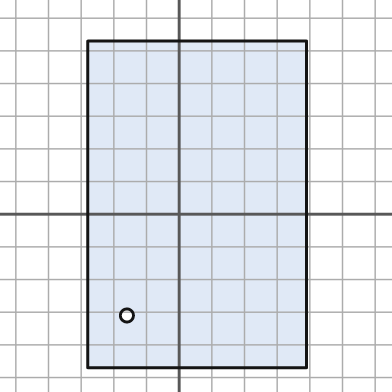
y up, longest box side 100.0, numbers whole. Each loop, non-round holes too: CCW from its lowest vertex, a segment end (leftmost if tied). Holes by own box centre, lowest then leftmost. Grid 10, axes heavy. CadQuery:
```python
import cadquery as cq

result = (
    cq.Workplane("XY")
    .moveTo(-28.0, -47.0)
    .lineTo(39.0, -47.0)
    .lineTo(39.0, 53.0)
    .lineTo(-28.0, 53.0)
    .close()
    .moveTo(-16.0, -31.0)
    .circle(2.0)
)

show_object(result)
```